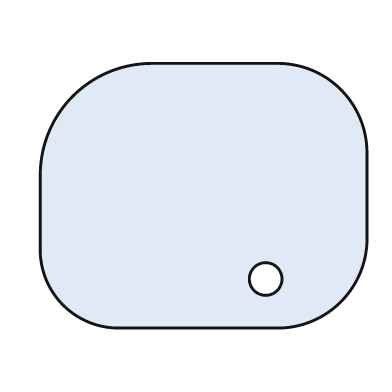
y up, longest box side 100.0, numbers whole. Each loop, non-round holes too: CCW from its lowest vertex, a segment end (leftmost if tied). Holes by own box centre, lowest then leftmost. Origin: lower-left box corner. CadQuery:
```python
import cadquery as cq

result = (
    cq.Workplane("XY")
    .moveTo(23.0, 0.0)
    .lineTo(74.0, 0.0)
    .threePointArc((92.0, 8.0), (100.0, 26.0))
    .lineTo(100.0, 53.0)
    .threePointArc((92.0, 73.0), (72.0, 81.0))
    .lineTo(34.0, 81.0)
    .threePointArc((10.0, 71.0), (0.0, 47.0))
    .lineTo(0.0, 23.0)
    .threePointArc((7.0, 7.0), (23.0, 0.0))
    .close()
    .moveTo(69.0, 15.0)
    .circle(5.0)
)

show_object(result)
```